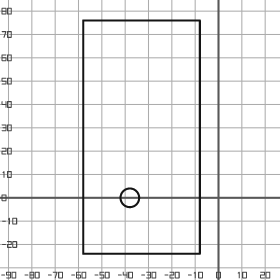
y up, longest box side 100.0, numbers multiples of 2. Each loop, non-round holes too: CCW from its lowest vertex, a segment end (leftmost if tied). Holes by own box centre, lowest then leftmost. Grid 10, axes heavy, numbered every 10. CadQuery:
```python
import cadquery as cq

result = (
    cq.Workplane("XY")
    .moveTo(-58.0, -24.0)
    .lineTo(-8.0, -24.0)
    .lineTo(-8.0, 76.0)
    .lineTo(-58.0, 76.0)
    .close()
    .moveTo(-38.0, 0.0)
    .circle(4.0)
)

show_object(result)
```